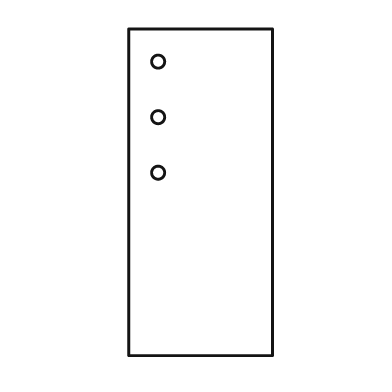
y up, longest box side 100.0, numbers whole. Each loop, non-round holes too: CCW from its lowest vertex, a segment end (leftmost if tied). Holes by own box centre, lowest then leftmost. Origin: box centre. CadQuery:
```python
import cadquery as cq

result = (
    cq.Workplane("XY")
    .moveTo(-22.0, -50.0)
    .lineTo(22.0, -50.0)
    .lineTo(22.0, 50.0)
    .lineTo(-22.0, 50.0)
    .close()
    .moveTo(-13.0, 6.0)
    .circle(2.0)
    .moveTo(-13.0, 23.0)
    .circle(2.0)
    .moveTo(-13.0, 40.0)
    .circle(2.0)
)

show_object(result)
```